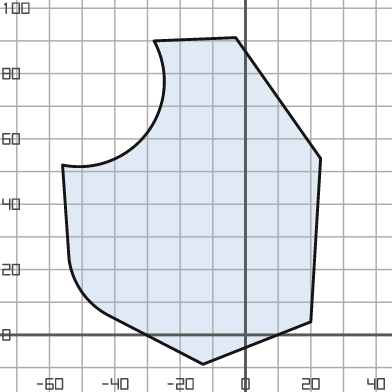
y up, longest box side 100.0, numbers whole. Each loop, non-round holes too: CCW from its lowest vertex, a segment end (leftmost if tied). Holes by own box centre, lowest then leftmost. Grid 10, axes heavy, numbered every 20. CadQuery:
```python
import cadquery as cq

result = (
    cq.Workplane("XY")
    .moveTo(-13.0, -9.0)
    .lineTo(20.0, 4.0)
    .lineTo(23.0, 54.0)
    .lineTo(-3.0, 91.0)
    .lineTo(-28.0, 90.0)
    .threePointArc((-30.0, 62.0), (-56.0, 52.0))
    .lineTo(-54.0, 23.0)
    .threePointArc((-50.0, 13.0), (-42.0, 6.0))
    .close()
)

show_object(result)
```